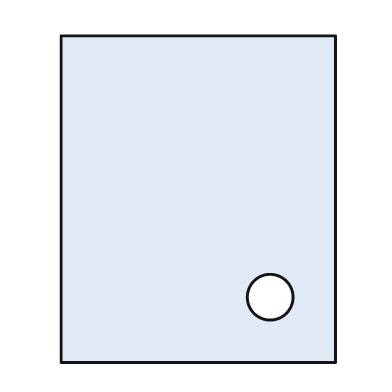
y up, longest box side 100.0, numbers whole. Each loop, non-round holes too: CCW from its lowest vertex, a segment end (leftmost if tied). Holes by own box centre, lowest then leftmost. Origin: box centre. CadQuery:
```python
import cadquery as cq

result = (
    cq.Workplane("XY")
    .moveTo(-42.0, -50.0)
    .lineTo(42.0, -50.0)
    .lineTo(42.0, 50.0)
    .lineTo(-42.0, 50.0)
    .close()
    .moveTo(22.0, -30.0)
    .circle(7.0)
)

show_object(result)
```